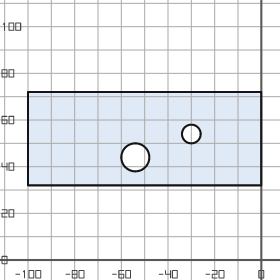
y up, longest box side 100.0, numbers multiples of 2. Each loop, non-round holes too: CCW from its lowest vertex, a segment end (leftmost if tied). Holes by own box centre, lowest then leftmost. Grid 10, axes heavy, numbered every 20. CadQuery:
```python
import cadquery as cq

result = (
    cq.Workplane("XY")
    .moveTo(-100.0, 32.0)
    .lineTo(0.0, 32.0)
    .lineTo(0.0, 72.0)
    .lineTo(-100.0, 72.0)
    .close()
    .moveTo(-54.0, 44.0)
    .circle(6.0)
    .moveTo(-30.0, 54.0)
    .circle(4.0)
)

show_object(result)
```